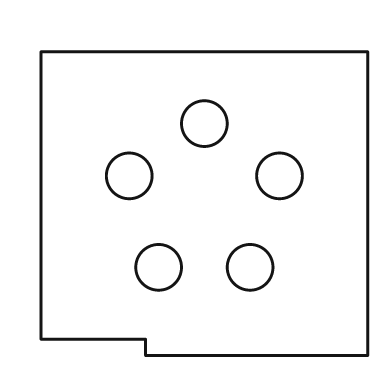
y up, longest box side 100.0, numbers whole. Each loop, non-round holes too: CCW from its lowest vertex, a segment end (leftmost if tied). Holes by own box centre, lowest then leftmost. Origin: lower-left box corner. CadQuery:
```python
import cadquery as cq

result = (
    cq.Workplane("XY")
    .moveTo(32.0, 0.0)
    .lineTo(100.0, 0.0)
    .lineTo(100.0, 93.0)
    .lineTo(0.0, 93.0)
    .lineTo(0.0, 5.0)
    .lineTo(32.0, 5.0)
    .close()
    .moveTo(36.0, 27.0)
    .circle(7.0)
    .moveTo(64.0, 27.0)
    .circle(7.0)
    .moveTo(27.0, 55.0)
    .circle(7.0)
    .moveTo(73.0, 55.0)
    .circle(7.0)
    .moveTo(50.0, 71.0)
    .circle(7.0)
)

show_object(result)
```